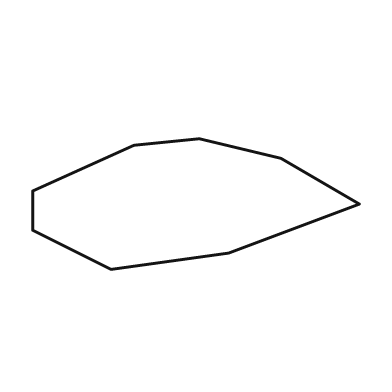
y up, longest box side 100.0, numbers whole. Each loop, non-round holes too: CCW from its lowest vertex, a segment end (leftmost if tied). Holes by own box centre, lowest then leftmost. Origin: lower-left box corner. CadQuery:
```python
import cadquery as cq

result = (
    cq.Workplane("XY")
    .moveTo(24.0, 0.0)
    .lineTo(60.0, 5.0)
    .lineTo(100.0, 20.0)
    .lineTo(76.0, 34.0)
    .lineTo(51.0, 40.0)
    .lineTo(31.0, 38.0)
    .lineTo(0.0, 24.0)
    .lineTo(0.0, 12.0)
    .close()
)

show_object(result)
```